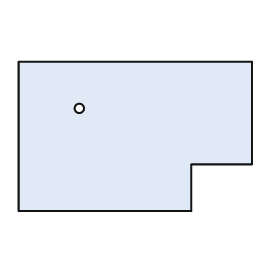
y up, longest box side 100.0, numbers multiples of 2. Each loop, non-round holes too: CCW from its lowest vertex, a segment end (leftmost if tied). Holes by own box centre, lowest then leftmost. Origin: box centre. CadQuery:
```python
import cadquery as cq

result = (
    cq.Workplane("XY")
    .moveTo(-50.0, -32.0)
    .lineTo(24.0, -32.0)
    .lineTo(24.0, -12.0)
    .lineTo(50.0, -12.0)
    .lineTo(50.0, 32.0)
    .lineTo(-50.0, 32.0)
    .close()
    .moveTo(-24.0, 12.0)
    .circle(2.0)
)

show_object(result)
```